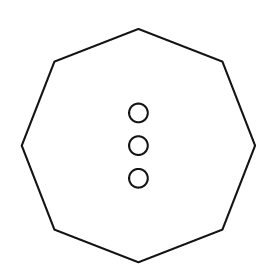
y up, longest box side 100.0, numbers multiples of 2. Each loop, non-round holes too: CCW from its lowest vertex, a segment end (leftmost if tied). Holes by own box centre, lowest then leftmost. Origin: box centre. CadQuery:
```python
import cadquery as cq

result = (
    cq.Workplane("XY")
    .moveTo(0.0, -50.0)
    .lineTo(36.0, -36.0)
    .lineTo(50.0, 0.0)
    .lineTo(36.0, 36.0)
    .lineTo(0.0, 50.0)
    .lineTo(-36.0, 36.0)
    .lineTo(-50.0, 0.0)
    .lineTo(-36.0, -36.0)
    .close()
    .moveTo(0.0, -14.0)
    .circle(4.0)
    .moveTo(0.0, 0.0)
    .circle(4.0)
    .moveTo(0.0, 14.0)
    .circle(4.0)
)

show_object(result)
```